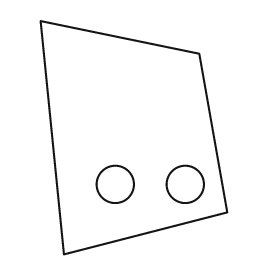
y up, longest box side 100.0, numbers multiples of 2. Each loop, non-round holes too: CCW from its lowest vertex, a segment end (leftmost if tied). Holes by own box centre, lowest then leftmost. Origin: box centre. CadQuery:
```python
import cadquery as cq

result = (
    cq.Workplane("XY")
    .moveTo(-30.0, -50.0)
    .lineTo(40.0, -32.0)
    .lineTo(28.0, 36.0)
    .lineTo(-40.0, 50.0)
    .close()
    .moveTo(-8.0, -20.0)
    .circle(8.0)
    .moveTo(22.0, -20.0)
    .circle(8.0)
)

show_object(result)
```